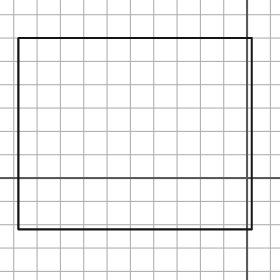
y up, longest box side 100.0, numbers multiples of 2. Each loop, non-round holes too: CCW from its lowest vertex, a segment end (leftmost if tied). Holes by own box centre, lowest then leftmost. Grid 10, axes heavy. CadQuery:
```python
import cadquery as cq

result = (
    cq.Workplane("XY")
    .moveTo(-98.0, -22.0)
    .lineTo(2.0, -22.0)
    .lineTo(2.0, 60.0)
    .lineTo(-98.0, 60.0)
    .close()
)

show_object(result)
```